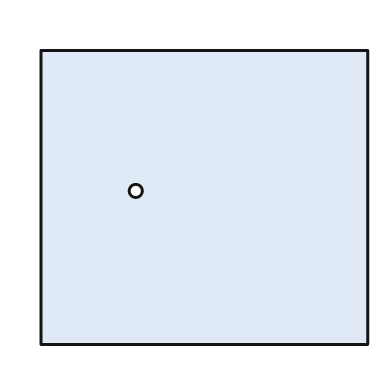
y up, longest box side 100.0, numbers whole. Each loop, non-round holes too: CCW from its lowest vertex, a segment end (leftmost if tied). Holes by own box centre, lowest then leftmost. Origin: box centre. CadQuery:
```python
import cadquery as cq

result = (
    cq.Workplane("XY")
    .moveTo(-50.0, -45.0)
    .lineTo(50.0, -45.0)
    .lineTo(50.0, 45.0)
    .lineTo(-50.0, 45.0)
    .close()
    .moveTo(-21.0, 2.0)
    .circle(2.0)
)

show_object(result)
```